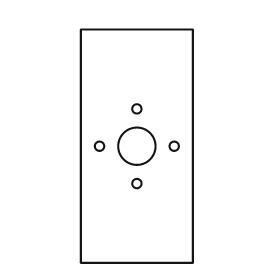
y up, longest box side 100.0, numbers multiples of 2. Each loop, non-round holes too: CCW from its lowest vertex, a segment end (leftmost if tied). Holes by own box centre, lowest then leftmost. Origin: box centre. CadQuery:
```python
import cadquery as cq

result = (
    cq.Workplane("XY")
    .moveTo(-24.0, -50.0)
    .lineTo(24.0, -50.0)
    .lineTo(24.0, 50.0)
    .lineTo(-24.0, 50.0)
    .close()
    .moveTo(0.0, -16.0)
    .circle(2.0)
    .moveTo(-16.0, 0.0)
    .circle(2.0)
    .moveTo(0.0, 0.0)
    .circle(8.0)
    .moveTo(16.0, 0.0)
    .circle(2.0)
    .moveTo(0.0, 16.0)
    .circle(2.0)
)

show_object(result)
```